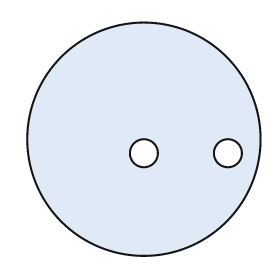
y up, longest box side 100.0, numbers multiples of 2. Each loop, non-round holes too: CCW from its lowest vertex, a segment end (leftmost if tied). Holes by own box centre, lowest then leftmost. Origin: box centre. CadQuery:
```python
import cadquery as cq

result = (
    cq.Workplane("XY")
    .moveTo(0.0, 0.0)
    .circle(50.0)
    .moveTo(0.0, -6.0)
    .circle(6.0)
    .moveTo(36.0, -6.0)
    .circle(6.0)
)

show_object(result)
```